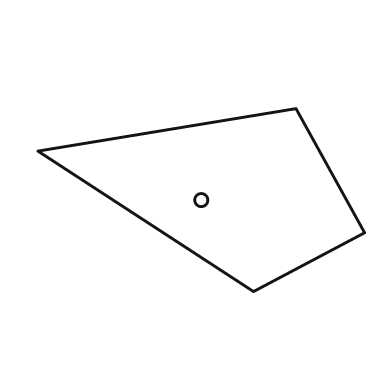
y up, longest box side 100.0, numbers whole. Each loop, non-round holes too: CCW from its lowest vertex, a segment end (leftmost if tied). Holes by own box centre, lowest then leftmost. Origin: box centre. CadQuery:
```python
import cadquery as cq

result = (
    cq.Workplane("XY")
    .moveTo(16.0, -28.0)
    .lineTo(50.0, -10.0)
    .lineTo(29.0, 28.0)
    .lineTo(-50.0, 15.0)
    .close()
    .moveTo(0.0, 0.0)
    .circle(2.0)
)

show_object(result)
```